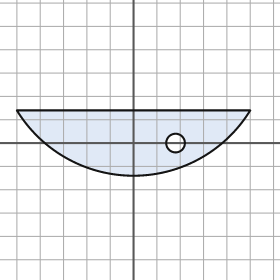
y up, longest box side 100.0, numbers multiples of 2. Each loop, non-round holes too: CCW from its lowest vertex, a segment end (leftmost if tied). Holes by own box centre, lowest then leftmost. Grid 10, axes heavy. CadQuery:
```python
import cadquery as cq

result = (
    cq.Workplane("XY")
    .moveTo(-50.0, 14.0)
    .threePointArc((0.0, -14.0), (50.0, 14.0))
    .close()
    .moveTo(18.0, 0.0)
    .circle(4.0)
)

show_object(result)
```